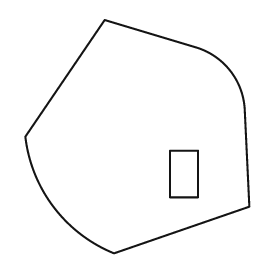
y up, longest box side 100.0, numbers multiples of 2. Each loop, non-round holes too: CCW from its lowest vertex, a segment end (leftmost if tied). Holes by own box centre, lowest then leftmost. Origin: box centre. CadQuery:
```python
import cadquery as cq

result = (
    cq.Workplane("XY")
    .moveTo(-10.0, -50.0)
    .lineTo(48.0, -30.0)
    .lineTo(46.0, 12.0)
    .threePointArc((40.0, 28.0), (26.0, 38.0))
    .lineTo(-14.0, 50.0)
    .lineTo(-48.0, 0.0)
    .threePointArc((-36.0, -30.0), (-10.0, -50.0))
    .close()
    .moveTo(14.0, -26.0)
    .lineTo(26.0, -26.0)
    .lineTo(26.0, -6.0)
    .lineTo(14.0, -6.0)
    .close()
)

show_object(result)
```